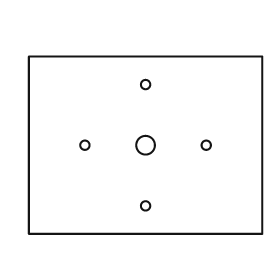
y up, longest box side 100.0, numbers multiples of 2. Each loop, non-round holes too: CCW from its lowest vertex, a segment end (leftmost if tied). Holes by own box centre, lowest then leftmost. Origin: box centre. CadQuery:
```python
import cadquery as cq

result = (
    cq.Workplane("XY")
    .moveTo(-50.0, -38.0)
    .lineTo(50.0, -38.0)
    .lineTo(50.0, 38.0)
    .lineTo(-50.0, 38.0)
    .close()
    .moveTo(0.0, -26.0)
    .circle(2.0)
    .moveTo(-26.0, 0.0)
    .circle(2.0)
    .moveTo(0.0, 0.0)
    .circle(4.0)
    .moveTo(26.0, 0.0)
    .circle(2.0)
    .moveTo(0.0, 26.0)
    .circle(2.0)
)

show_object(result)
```